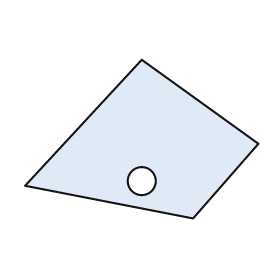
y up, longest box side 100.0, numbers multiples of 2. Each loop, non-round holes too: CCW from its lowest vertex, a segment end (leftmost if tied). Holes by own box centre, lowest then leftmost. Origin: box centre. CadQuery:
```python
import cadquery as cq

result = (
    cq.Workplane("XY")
    .moveTo(22.0, -34.0)
    .lineTo(50.0, -2.0)
    .lineTo(0.0, 34.0)
    .lineTo(-50.0, -20.0)
    .close()
    .moveTo(0.0, -18.0)
    .circle(6.0)
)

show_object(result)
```